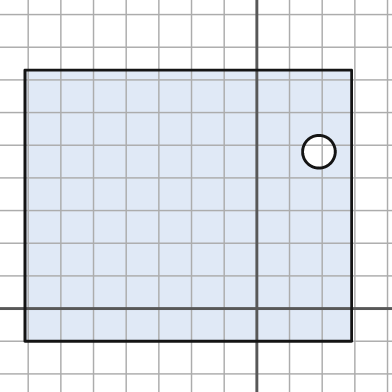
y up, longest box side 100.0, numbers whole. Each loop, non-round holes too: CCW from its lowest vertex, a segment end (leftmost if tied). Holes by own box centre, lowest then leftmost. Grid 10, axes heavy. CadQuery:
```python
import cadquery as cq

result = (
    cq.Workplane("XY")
    .moveTo(-71.0, -10.0)
    .lineTo(29.0, -10.0)
    .lineTo(29.0, 73.0)
    .lineTo(-71.0, 73.0)
    .close()
    .moveTo(19.0, 48.0)
    .circle(5.0)
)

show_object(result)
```